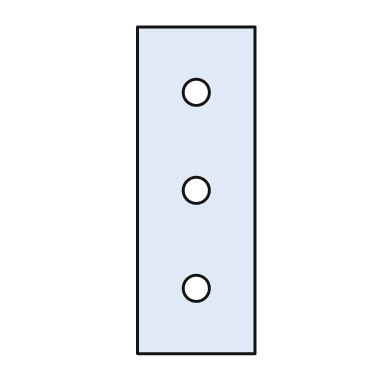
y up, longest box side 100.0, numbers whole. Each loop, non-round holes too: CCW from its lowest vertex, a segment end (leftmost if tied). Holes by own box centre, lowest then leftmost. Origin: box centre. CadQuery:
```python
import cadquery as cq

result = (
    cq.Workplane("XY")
    .moveTo(-18.0, -50.0)
    .lineTo(18.0, -50.0)
    .lineTo(18.0, 50.0)
    .lineTo(-18.0, 50.0)
    .close()
    .moveTo(0.0, -30.0)
    .circle(4.0)
    .moveTo(0.0, 0.0)
    .circle(4.0)
    .moveTo(0.0, 30.0)
    .circle(4.0)
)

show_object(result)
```